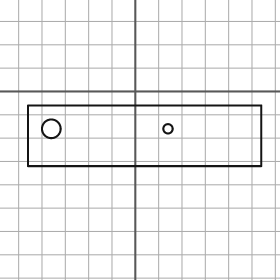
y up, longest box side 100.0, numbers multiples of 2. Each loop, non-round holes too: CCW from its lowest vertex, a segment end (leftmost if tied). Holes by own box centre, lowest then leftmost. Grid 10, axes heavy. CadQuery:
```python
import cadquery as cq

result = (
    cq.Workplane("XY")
    .moveTo(-46.0, -32.0)
    .lineTo(54.0, -32.0)
    .lineTo(54.0, -6.0)
    .lineTo(-46.0, -6.0)
    .close()
    .moveTo(-36.0, -16.0)
    .circle(4.0)
    .moveTo(14.0, -16.0)
    .circle(2.0)
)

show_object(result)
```